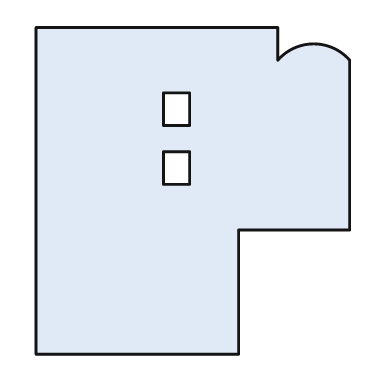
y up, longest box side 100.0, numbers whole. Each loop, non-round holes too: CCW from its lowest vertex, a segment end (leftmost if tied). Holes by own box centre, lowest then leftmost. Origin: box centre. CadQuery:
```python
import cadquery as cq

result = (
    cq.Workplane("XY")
    .moveTo(-48.0, -50.0)
    .lineTo(14.0, -50.0)
    .lineTo(14.0, -12.0)
    .lineTo(48.0, -12.0)
    .lineTo(48.0, 40.0)
    .threePointArc((37.0, 45.0), (26.0, 40.0))
    .lineTo(26.0, 50.0)
    .lineTo(-48.0, 50.0)
    .close()
    .moveTo(-9.0, 2.0)
    .lineTo(-1.0, 2.0)
    .lineTo(-1.0, 12.0)
    .lineTo(-9.0, 12.0)
    .close()
    .moveTo(-9.0, 20.0)
    .lineTo(-1.0, 20.0)
    .lineTo(-1.0, 30.0)
    .lineTo(-9.0, 30.0)
    .close()
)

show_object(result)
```